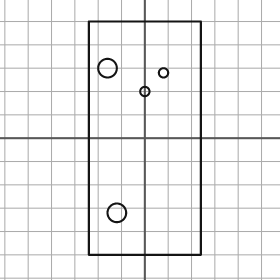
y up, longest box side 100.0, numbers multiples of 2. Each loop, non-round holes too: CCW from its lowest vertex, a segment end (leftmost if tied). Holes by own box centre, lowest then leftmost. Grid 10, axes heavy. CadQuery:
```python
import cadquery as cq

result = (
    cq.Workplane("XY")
    .moveTo(-24.0, -50.0)
    .lineTo(24.0, -50.0)
    .lineTo(24.0, 50.0)
    .lineTo(-24.0, 50.0)
    .close()
    .moveTo(-12.0, -32.0)
    .circle(4.0)
    .moveTo(0.0, 20.0)
    .circle(2.0)
    .moveTo(8.0, 28.0)
    .circle(2.0)
    .moveTo(-16.0, 30.0)
    .circle(4.0)
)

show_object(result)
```